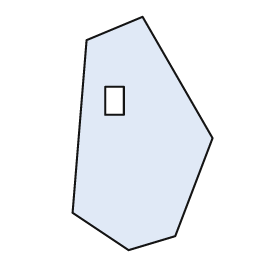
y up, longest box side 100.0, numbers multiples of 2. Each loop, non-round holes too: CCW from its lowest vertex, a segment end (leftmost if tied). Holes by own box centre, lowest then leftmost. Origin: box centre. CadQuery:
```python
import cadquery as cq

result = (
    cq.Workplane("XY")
    .moveTo(-6.0, -50.0)
    .lineTo(14.0, -44.0)
    .lineTo(30.0, -2.0)
    .lineTo(0.0, 50.0)
    .lineTo(-24.0, 40.0)
    .lineTo(-30.0, -34.0)
    .close()
    .moveTo(-16.0, 8.0)
    .lineTo(-8.0, 8.0)
    .lineTo(-8.0, 20.0)
    .lineTo(-16.0, 20.0)
    .close()
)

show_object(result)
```